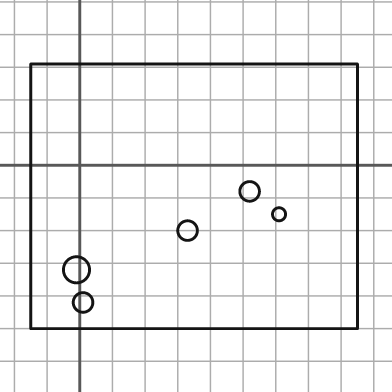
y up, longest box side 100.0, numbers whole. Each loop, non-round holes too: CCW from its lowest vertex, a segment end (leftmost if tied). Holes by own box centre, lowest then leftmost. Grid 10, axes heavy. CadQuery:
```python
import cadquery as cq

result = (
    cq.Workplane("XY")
    .moveTo(-15.0, -50.0)
    .lineTo(85.0, -50.0)
    .lineTo(85.0, 31.0)
    .lineTo(-15.0, 31.0)
    .close()
    .moveTo(1.0, -42.0)
    .circle(3.0)
    .moveTo(-1.0, -32.0)
    .circle(4.0)
    .moveTo(33.0, -20.0)
    .circle(3.0)
    .moveTo(61.0, -15.0)
    .circle(2.0)
    .moveTo(52.0, -8.0)
    .circle(3.0)
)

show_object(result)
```